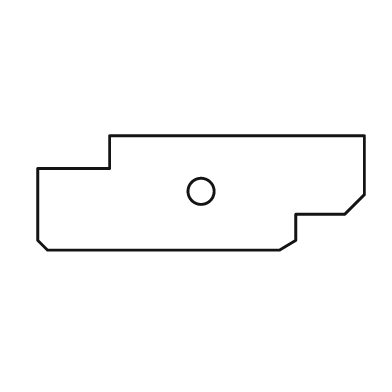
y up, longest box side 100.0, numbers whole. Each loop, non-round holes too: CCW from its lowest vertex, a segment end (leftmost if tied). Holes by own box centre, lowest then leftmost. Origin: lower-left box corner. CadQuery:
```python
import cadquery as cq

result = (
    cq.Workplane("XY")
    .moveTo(3.0, 0.0)
    .lineTo(74.0, 0.0)
    .lineTo(79.0, 3.0)
    .lineTo(79.0, 11.0)
    .lineTo(94.0, 11.0)
    .lineTo(100.0, 17.0)
    .lineTo(100.0, 35.0)
    .lineTo(22.0, 35.0)
    .lineTo(22.0, 25.0)
    .lineTo(0.0, 25.0)
    .lineTo(0.0, 3.0)
    .close()
    .moveTo(50.0, 18.0)
    .circle(4.0)
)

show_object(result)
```